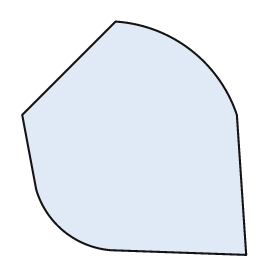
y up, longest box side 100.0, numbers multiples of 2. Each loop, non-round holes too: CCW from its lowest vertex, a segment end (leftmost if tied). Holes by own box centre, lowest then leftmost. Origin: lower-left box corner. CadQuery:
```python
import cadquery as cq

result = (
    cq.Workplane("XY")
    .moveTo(96.0, 0.0)
    .lineTo(92.0, 60.0)
    .threePointArc((72.0, 88.0), (40.0, 100.0))
    .lineTo(0.0, 60.0)
    .lineTo(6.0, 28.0)
    .threePointArc((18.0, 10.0), (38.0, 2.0))
    .close()
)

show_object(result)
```